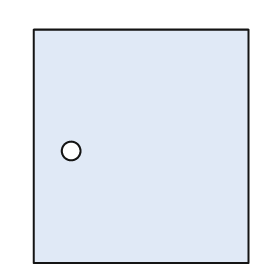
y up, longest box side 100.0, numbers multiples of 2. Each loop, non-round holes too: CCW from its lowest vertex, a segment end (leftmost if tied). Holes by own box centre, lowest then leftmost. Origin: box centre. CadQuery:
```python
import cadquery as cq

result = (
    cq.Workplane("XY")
    .moveTo(-46.0, -50.0)
    .lineTo(46.0, -50.0)
    .lineTo(46.0, 50.0)
    .lineTo(-46.0, 50.0)
    .close()
    .moveTo(-30.0, -2.0)
    .circle(4.0)
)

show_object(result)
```